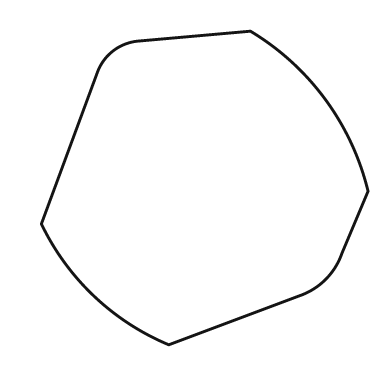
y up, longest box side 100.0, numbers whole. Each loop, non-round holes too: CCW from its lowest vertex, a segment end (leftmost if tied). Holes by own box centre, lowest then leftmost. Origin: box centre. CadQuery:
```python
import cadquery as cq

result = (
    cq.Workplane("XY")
    .moveTo(-11.0, -48.0)
    .lineTo(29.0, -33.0)
    .threePointArc((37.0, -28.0), (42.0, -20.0))
    .lineTo(50.0, -1.0)
    .threePointArc((37.0, 27.0), (14.0, 48.0))
    .lineTo(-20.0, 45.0)
    .threePointArc((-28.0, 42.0), (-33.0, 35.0))
    .lineTo(-50.0, -11.0)
    .threePointArc((-34.0, -33.0), (-11.0, -48.0))
    .close()
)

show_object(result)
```